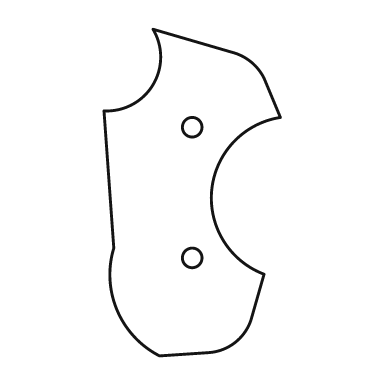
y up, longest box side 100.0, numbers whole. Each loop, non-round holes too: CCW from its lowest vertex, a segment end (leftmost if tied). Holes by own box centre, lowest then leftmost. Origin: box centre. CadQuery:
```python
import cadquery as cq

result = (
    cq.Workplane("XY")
    .moveTo(-10.0, -50.0)
    .lineTo(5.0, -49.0)
    .threePointArc((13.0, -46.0), (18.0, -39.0))
    .lineTo(22.0, -25.0)
    .threePointArc((6.0, 1.0), (27.0, 23.0))
    .lineTo(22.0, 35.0)
    .threePointArc((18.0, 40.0), (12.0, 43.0))
    .lineTo(-12.0, 50.0)
    .threePointArc((-12.0, 33.0), (-27.0, 25.0))
    .lineTo(-24.0, -17.0)
    .threePointArc((-23.0, -36.0), (-10.0, -50.0))
    .close()
    .moveTo(0.0, -20.0)
    .circle(3.0)
    .moveTo(0.0, 20.0)
    .circle(3.0)
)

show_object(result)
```